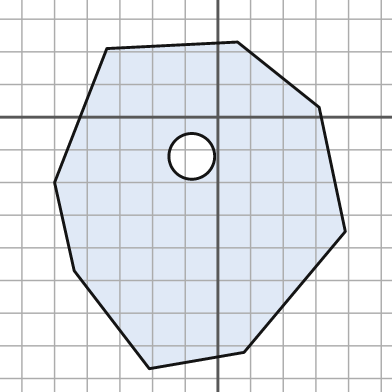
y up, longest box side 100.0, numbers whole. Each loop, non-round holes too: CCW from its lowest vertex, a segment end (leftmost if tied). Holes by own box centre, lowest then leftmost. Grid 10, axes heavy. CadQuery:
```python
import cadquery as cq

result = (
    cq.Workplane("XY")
    .moveTo(-21.0, -77.0)
    .lineTo(8.0, -72.0)
    .lineTo(39.0, -35.0)
    .lineTo(31.0, 3.0)
    .lineTo(6.0, 23.0)
    .lineTo(-34.0, 21.0)
    .lineTo(-50.0, -20.0)
    .lineTo(-44.0, -47.0)
    .close()
    .moveTo(-8.0, -12.0)
    .circle(7.0)
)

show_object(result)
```